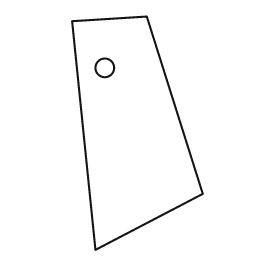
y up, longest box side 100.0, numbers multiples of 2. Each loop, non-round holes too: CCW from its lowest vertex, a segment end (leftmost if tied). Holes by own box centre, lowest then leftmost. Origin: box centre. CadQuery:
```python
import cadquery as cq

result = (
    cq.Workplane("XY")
    .moveTo(-18.0, -50.0)
    .lineTo(28.0, -26.0)
    .lineTo(4.0, 50.0)
    .lineTo(-28.0, 48.0)
    .close()
    .moveTo(-14.0, 28.0)
    .circle(4.0)
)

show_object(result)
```